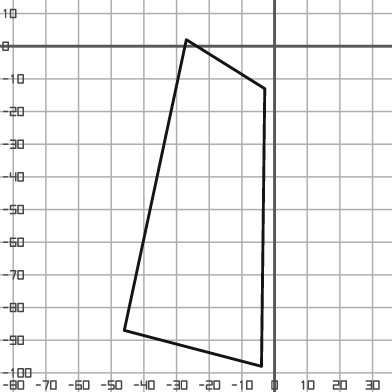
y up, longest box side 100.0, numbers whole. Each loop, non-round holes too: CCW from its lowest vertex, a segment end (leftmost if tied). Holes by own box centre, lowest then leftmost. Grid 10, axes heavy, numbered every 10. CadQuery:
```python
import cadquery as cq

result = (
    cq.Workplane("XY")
    .moveTo(-4.0, -98.0)
    .lineTo(-3.0, -13.0)
    .lineTo(-27.0, 2.0)
    .lineTo(-46.0, -87.0)
    .close()
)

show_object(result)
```